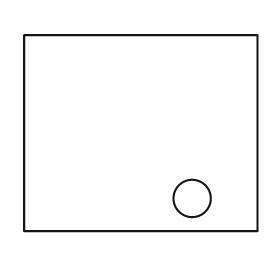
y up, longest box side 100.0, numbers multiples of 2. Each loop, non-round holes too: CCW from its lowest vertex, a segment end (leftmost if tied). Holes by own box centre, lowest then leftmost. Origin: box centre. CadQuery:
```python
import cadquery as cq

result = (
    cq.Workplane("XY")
    .moveTo(-50.0, -42.0)
    .lineTo(50.0, -42.0)
    .lineTo(50.0, 42.0)
    .lineTo(-50.0, 42.0)
    .close()
    .moveTo(22.0, -28.0)
    .circle(8.0)
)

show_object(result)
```